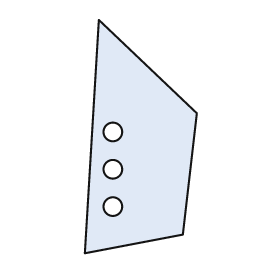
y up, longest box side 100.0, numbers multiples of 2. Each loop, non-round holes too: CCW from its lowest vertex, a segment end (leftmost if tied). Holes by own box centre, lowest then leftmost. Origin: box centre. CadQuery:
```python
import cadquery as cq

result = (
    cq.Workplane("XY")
    .moveTo(-24.0, -50.0)
    .lineTo(18.0, -42.0)
    .lineTo(24.0, 10.0)
    .lineTo(-18.0, 50.0)
    .close()
    .moveTo(-12.0, -30.0)
    .circle(4.0)
    .moveTo(-12.0, -14.0)
    .circle(4.0)
    .moveTo(-12.0, 2.0)
    .circle(4.0)
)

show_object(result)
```